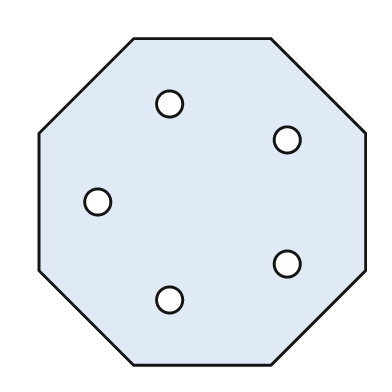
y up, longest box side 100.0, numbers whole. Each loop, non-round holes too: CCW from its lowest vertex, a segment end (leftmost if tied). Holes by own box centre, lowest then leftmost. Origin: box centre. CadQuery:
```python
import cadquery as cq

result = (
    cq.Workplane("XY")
    .moveTo(-21.0, -50.0)
    .lineTo(21.0, -50.0)
    .lineTo(50.0, -21.0)
    .lineTo(50.0, 21.0)
    .lineTo(21.0, 50.0)
    .lineTo(-21.0, 50.0)
    .lineTo(-50.0, 21.0)
    .lineTo(-50.0, -21.0)
    .close()
    .moveTo(-10.0, -30.0)
    .circle(4.0)
    .moveTo(26.0, -19.0)
    .circle(4.0)
    .moveTo(-32.0, 0.0)
    .circle(4.0)
    .moveTo(26.0, 19.0)
    .circle(4.0)
    .moveTo(-10.0, 30.0)
    .circle(4.0)
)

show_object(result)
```